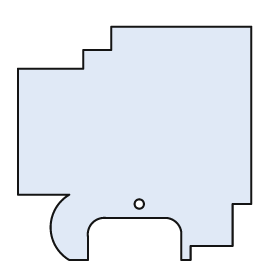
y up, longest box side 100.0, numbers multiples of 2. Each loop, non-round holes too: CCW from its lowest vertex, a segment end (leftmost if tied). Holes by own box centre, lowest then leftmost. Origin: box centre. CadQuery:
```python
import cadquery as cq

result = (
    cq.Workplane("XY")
    .moveTo(-28.0, -50.0)
    .lineTo(-20.0, -50.0)
    .lineTo(-20.0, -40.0)
    .threePointArc((-18.0, -34.0), (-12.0, -32.0))
    .lineTo(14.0, -32.0)
    .threePointArc((18.0, -34.0), (20.0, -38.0))
    .lineTo(20.0, -50.0)
    .lineTo(24.0, -50.0)
    .lineTo(24.0, -44.0)
    .lineTo(42.0, -44.0)
    .lineTo(42.0, -26.0)
    .lineTo(50.0, -26.0)
    .lineTo(50.0, 50.0)
    .lineTo(-10.0, 50.0)
    .lineTo(-10.0, 40.0)
    .lineTo(-22.0, 40.0)
    .lineTo(-22.0, 32.0)
    .lineTo(-50.0, 32.0)
    .lineTo(-50.0, -22.0)
    .lineTo(-28.0, -22.0)
    .threePointArc((-36.0, -36.0), (-28.0, -50.0))
    .close()
    .moveTo(2.0, -26.0)
    .circle(2.0)
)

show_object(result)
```